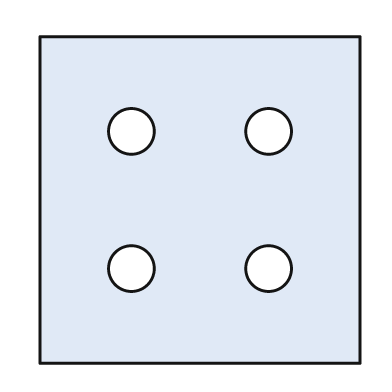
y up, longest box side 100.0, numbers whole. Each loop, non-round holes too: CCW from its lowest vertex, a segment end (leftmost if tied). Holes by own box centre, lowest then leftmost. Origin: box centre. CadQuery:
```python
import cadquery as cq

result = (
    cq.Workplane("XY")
    .moveTo(-49.0, -50.0)
    .lineTo(49.0, -50.0)
    .lineTo(49.0, 50.0)
    .lineTo(-49.0, 50.0)
    .close()
    .moveTo(-21.0, -21.0)
    .circle(7.0)
    .moveTo(21.0, -21.0)
    .circle(7.0)
    .moveTo(-21.0, 21.0)
    .circle(7.0)
    .moveTo(21.0, 21.0)
    .circle(7.0)
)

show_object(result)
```